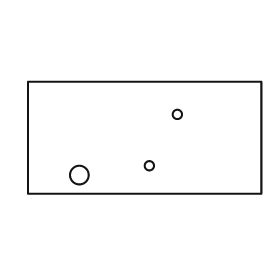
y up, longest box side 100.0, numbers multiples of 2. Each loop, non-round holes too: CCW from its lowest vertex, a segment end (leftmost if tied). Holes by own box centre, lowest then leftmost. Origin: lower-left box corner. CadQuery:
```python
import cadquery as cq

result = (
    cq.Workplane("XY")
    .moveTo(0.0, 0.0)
    .lineTo(100.0, 0.0)
    .lineTo(100.0, 48.0)
    .lineTo(0.0, 48.0)
    .close()
    .moveTo(22.0, 8.0)
    .circle(4.0)
    .moveTo(52.0, 12.0)
    .circle(2.0)
    .moveTo(64.0, 34.0)
    .circle(2.0)
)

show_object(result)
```